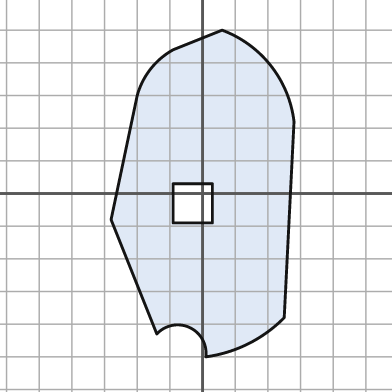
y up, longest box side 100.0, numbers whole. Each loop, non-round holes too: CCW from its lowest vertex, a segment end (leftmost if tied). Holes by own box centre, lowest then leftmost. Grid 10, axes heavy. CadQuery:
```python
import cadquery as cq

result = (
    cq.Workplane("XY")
    .moveTo(1.0, -50.0)
    .threePointArc((14.0, -46.0), (25.0, -38.0))
    .lineTo(28.0, 22.0)
    .threePointArc((21.0, 39.0), (6.0, 50.0))
    .lineTo(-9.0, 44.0)
    .threePointArc((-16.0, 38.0), (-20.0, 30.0))
    .lineTo(-28.0, -8.0)
    .lineTo(-14.0, -43.0)
    .threePointArc((-4.0, -41.0), (1.0, -50.0))
    .close()
    .moveTo(-9.0, -9.0)
    .lineTo(3.0, -9.0)
    .lineTo(3.0, 3.0)
    .lineTo(-9.0, 3.0)
    .close()
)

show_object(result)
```